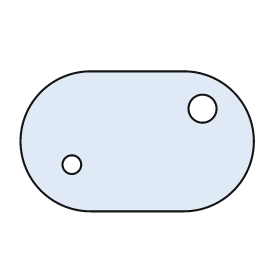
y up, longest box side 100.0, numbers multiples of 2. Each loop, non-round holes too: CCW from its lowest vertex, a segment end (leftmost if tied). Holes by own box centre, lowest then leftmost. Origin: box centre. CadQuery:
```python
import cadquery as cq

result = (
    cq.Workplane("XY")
    .moveTo(-20.0, -30.0)
    .lineTo(20.0, -30.0)
    .threePointArc((50.0, 0.0), (20.0, 30.0))
    .lineTo(-20.0, 30.0)
    .threePointArc((-50.0, 0.0), (-20.0, -30.0))
    .close()
    .moveTo(-28.0, -10.0)
    .circle(4.0)
    .moveTo(28.0, 14.0)
    .circle(6.0)
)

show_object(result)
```